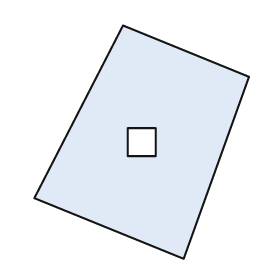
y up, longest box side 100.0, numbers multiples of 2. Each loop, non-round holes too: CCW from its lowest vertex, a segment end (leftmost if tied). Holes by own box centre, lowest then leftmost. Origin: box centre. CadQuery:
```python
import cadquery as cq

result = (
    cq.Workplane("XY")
    .moveTo(18.0, -50.0)
    .lineTo(46.0, 28.0)
    .lineTo(-8.0, 50.0)
    .lineTo(-46.0, -24.0)
    .close()
    .moveTo(-6.0, -6.0)
    .lineTo(6.0, -6.0)
    .lineTo(6.0, 6.0)
    .lineTo(-6.0, 6.0)
    .close()
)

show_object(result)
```